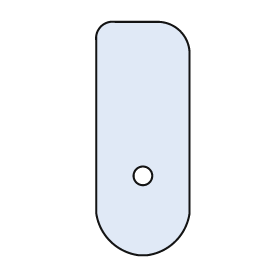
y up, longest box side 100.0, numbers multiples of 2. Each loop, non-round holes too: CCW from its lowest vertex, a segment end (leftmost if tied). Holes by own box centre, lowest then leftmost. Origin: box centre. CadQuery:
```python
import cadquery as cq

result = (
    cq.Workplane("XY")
    .moveTo(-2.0, -50.0)
    .lineTo(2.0, -50.0)
    .threePointArc((14.0, -44.0), (20.0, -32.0))
    .lineTo(20.0, 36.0)
    .threePointArc((16.0, 46.0), (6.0, 50.0))
    .lineTo(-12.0, 50.0)
    .threePointArc((-18.0, 48.0), (-20.0, 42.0))
    .lineTo(-20.0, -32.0)
    .threePointArc((-14.0, -44.0), (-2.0, -50.0))
    .close()
    .moveTo(0.0, -16.0)
    .circle(4.0)
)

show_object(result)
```